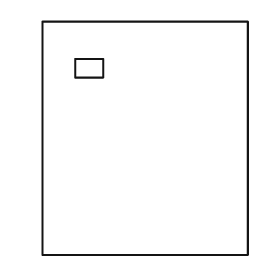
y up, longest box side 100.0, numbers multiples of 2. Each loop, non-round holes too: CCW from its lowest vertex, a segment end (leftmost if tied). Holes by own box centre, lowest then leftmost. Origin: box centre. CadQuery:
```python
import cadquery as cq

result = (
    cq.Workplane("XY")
    .moveTo(-44.0, -50.0)
    .lineTo(44.0, -50.0)
    .lineTo(44.0, 50.0)
    .lineTo(-44.0, 50.0)
    .close()
    .moveTo(-30.0, 26.0)
    .lineTo(-18.0, 26.0)
    .lineTo(-18.0, 34.0)
    .lineTo(-30.0, 34.0)
    .close()
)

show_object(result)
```